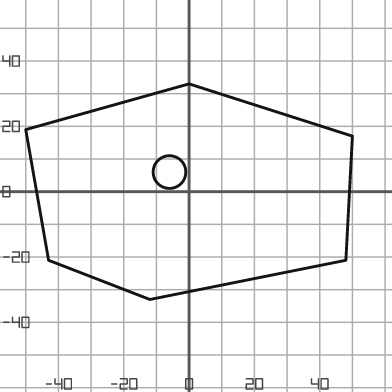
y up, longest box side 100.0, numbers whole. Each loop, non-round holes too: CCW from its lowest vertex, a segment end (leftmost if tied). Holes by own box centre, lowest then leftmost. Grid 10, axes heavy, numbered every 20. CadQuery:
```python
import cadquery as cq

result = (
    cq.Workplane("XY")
    .moveTo(-12.0, -33.0)
    .lineTo(48.0, -21.0)
    .lineTo(50.0, 17.0)
    .lineTo(0.0, 33.0)
    .lineTo(-50.0, 19.0)
    .lineTo(-43.0, -21.0)
    .close()
    .moveTo(-6.0, 6.0)
    .circle(5.0)
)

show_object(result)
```